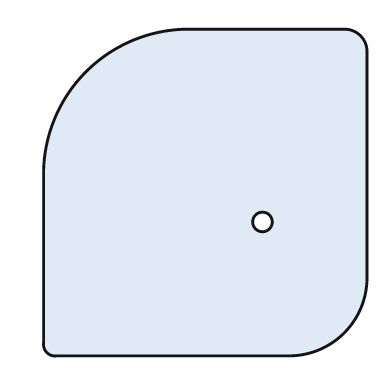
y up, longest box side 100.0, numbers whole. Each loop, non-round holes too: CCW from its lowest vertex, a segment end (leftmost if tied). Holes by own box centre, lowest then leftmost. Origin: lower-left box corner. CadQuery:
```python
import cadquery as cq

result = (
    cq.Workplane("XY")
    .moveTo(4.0, 0.0)
    .lineTo(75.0, 0.0)
    .threePointArc((92.0, 7.0), (99.0, 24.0))
    .lineTo(99.0, 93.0)
    .threePointArc((97.0, 98.0), (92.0, 100.0))
    .lineTo(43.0, 100.0)
    .threePointArc((13.0, 87.0), (0.0, 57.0))
    .lineTo(0.0, 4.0)
    .threePointArc((1.0, 1.0), (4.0, 0.0))
    .close()
    .moveTo(67.0, 41.0)
    .circle(3.0)
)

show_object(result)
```